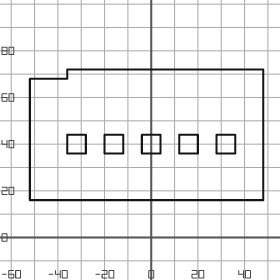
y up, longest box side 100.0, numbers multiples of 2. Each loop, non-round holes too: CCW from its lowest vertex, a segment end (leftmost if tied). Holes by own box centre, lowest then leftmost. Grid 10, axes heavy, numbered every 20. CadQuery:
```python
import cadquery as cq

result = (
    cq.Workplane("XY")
    .moveTo(-52.0, 16.0)
    .lineTo(48.0, 16.0)
    .lineTo(48.0, 72.0)
    .lineTo(-36.0, 72.0)
    .lineTo(-36.0, 68.0)
    .lineTo(-52.0, 68.0)
    .close()
    .moveTo(-36.0, 36.0)
    .lineTo(-28.0, 36.0)
    .lineTo(-28.0, 44.0)
    .lineTo(-36.0, 44.0)
    .close()
    .moveTo(-20.0, 36.0)
    .lineTo(-12.0, 36.0)
    .lineTo(-12.0, 44.0)
    .lineTo(-20.0, 44.0)
    .close()
    .moveTo(-4.0, 36.0)
    .lineTo(4.0, 36.0)
    .lineTo(4.0, 44.0)
    .lineTo(-4.0, 44.0)
    .close()
    .moveTo(12.0, 36.0)
    .lineTo(20.0, 36.0)
    .lineTo(20.0, 44.0)
    .lineTo(12.0, 44.0)
    .close()
    .moveTo(28.0, 36.0)
    .lineTo(36.0, 36.0)
    .lineTo(36.0, 44.0)
    .lineTo(28.0, 44.0)
    .close()
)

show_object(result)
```